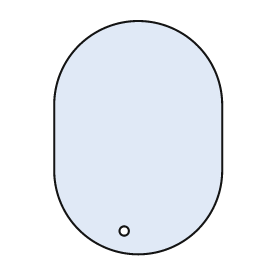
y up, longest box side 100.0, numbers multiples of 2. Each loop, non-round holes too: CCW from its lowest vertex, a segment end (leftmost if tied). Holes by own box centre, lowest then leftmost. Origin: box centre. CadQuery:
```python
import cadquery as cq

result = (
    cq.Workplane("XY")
    .moveTo(-36.0, -14.0)
    .threePointArc((0.0, -50.0), (36.0, -14.0))
    .lineTo(36.0, 14.0)
    .threePointArc((0.0, 50.0), (-36.0, 14.0))
    .close()
    .moveTo(-6.0, -40.0)
    .circle(2.0)
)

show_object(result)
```